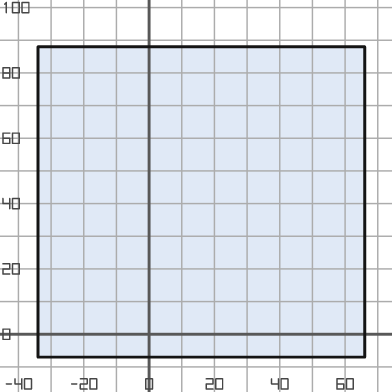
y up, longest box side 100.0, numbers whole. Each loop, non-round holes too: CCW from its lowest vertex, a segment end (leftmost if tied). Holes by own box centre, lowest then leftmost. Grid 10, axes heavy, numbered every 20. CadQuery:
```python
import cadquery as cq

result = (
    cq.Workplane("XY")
    .moveTo(-34.0, -7.0)
    .lineTo(66.0, -7.0)
    .lineTo(66.0, 88.0)
    .lineTo(-34.0, 88.0)
    .close()
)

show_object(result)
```